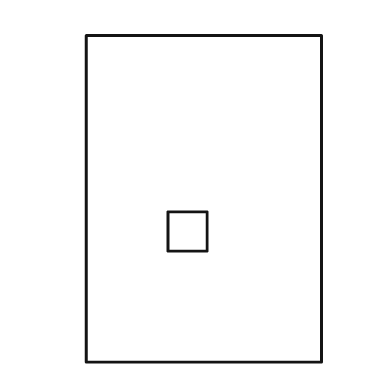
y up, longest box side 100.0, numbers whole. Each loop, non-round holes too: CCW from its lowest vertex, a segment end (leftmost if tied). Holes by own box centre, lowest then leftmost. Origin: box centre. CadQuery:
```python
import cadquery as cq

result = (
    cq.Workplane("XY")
    .moveTo(-36.0, -50.0)
    .lineTo(36.0, -50.0)
    .lineTo(36.0, 50.0)
    .lineTo(-36.0, 50.0)
    .close()
    .moveTo(-11.0, -16.0)
    .lineTo(1.0, -16.0)
    .lineTo(1.0, -4.0)
    .lineTo(-11.0, -4.0)
    .close()
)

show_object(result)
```